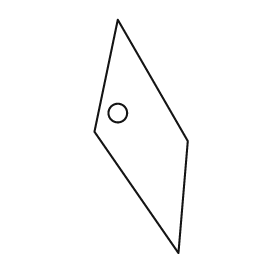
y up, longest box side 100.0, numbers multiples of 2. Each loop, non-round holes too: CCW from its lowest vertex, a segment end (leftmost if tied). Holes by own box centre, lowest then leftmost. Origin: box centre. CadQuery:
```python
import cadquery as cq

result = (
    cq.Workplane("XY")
    .moveTo(16.0, -50.0)
    .lineTo(20.0, -2.0)
    .lineTo(-10.0, 50.0)
    .lineTo(-20.0, 2.0)
    .close()
    .moveTo(-10.0, 10.0)
    .circle(4.0)
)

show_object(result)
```